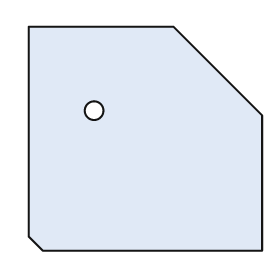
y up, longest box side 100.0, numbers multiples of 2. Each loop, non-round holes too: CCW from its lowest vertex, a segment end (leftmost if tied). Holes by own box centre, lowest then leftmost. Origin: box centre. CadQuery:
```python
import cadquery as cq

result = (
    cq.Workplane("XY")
    .moveTo(-44.0, -48.0)
    .lineTo(50.0, -48.0)
    .lineTo(50.0, 10.0)
    .lineTo(12.0, 48.0)
    .lineTo(-50.0, 48.0)
    .lineTo(-50.0, -42.0)
    .close()
    .moveTo(-22.0, 12.0)
    .circle(4.0)
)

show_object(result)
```